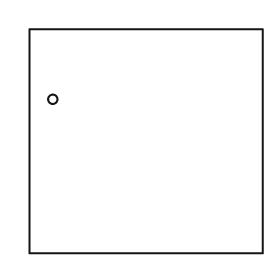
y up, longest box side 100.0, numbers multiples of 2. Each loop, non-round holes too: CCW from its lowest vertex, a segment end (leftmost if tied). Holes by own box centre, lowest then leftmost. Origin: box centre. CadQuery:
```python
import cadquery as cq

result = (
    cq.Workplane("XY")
    .moveTo(-50.0, -48.0)
    .lineTo(50.0, -48.0)
    .lineTo(50.0, 48.0)
    .lineTo(-50.0, 48.0)
    .close()
    .moveTo(-40.0, 18.0)
    .circle(2.0)
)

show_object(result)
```